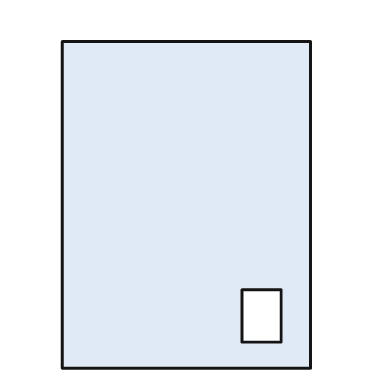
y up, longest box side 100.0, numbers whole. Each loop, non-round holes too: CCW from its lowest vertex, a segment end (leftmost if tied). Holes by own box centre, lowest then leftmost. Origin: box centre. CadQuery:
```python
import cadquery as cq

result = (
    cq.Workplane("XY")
    .moveTo(-38.0, -50.0)
    .lineTo(38.0, -50.0)
    .lineTo(38.0, 50.0)
    .lineTo(-38.0, 50.0)
    .close()
    .moveTo(17.0, -42.0)
    .lineTo(29.0, -42.0)
    .lineTo(29.0, -26.0)
    .lineTo(17.0, -26.0)
    .close()
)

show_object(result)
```